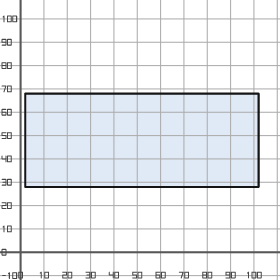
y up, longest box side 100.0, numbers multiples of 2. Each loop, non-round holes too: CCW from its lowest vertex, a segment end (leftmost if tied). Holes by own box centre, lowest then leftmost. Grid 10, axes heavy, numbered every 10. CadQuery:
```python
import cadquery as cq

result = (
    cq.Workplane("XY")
    .moveTo(2.0, 28.0)
    .lineTo(102.0, 28.0)
    .lineTo(102.0, 68.0)
    .lineTo(2.0, 68.0)
    .close()
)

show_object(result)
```